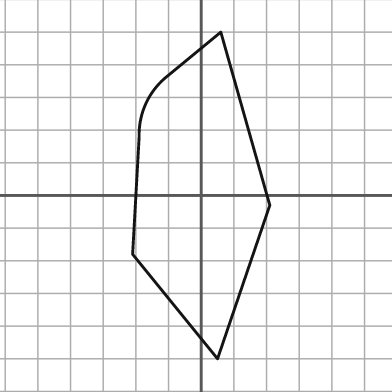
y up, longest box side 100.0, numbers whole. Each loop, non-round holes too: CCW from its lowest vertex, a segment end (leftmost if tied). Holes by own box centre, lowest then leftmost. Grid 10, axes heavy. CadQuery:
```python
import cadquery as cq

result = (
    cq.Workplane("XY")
    .moveTo(5.0, -50.0)
    .lineTo(21.0, -3.0)
    .lineTo(6.0, 50.0)
    .lineTo(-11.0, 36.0)
    .threePointArc((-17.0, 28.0), (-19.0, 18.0))
    .lineTo(-21.0, -18.0)
    .close()
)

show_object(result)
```